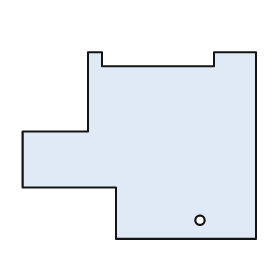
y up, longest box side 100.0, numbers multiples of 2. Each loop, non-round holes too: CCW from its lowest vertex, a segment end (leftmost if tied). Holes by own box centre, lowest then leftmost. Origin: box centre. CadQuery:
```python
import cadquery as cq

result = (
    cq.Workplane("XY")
    .moveTo(-10.0, -40.0)
    .lineTo(50.0, -40.0)
    .lineTo(50.0, 40.0)
    .lineTo(32.0, 40.0)
    .lineTo(32.0, 34.0)
    .lineTo(-16.0, 34.0)
    .lineTo(-16.0, 40.0)
    .lineTo(-22.0, 40.0)
    .lineTo(-22.0, 6.0)
    .lineTo(-50.0, 6.0)
    .lineTo(-50.0, -18.0)
    .lineTo(-10.0, -18.0)
    .close()
    .moveTo(26.0, -32.0)
    .circle(2.0)
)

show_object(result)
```